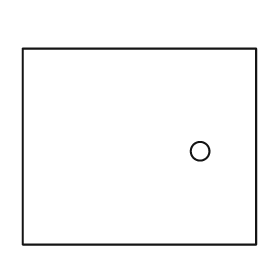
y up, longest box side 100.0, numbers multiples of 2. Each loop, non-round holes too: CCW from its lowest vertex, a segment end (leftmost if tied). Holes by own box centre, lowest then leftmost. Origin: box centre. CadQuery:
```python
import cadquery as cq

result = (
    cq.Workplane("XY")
    .moveTo(-50.0, -42.0)
    .lineTo(50.0, -42.0)
    .lineTo(50.0, 42.0)
    .lineTo(-50.0, 42.0)
    .close()
    .moveTo(26.0, -2.0)
    .circle(4.0)
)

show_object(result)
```